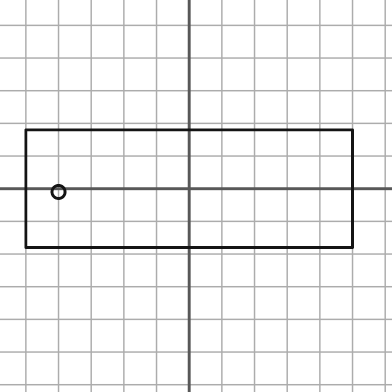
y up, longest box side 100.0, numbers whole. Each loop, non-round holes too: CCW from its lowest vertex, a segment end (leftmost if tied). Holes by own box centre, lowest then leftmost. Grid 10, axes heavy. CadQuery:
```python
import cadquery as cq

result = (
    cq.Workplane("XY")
    .moveTo(-50.0, -18.0)
    .lineTo(50.0, -18.0)
    .lineTo(50.0, 18.0)
    .lineTo(-50.0, 18.0)
    .close()
    .moveTo(-40.0, -1.0)
    .circle(2.0)
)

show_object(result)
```